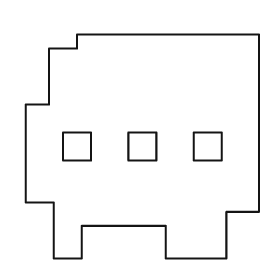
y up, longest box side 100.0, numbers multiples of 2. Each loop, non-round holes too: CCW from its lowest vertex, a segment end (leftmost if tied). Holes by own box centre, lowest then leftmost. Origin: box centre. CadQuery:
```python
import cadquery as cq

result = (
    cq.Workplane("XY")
    .moveTo(-38.0, -48.0)
    .lineTo(-26.0, -48.0)
    .lineTo(-26.0, -34.0)
    .lineTo(10.0, -34.0)
    .lineTo(10.0, -48.0)
    .lineTo(36.0, -48.0)
    .lineTo(36.0, -28.0)
    .lineTo(50.0, -28.0)
    .lineTo(50.0, 48.0)
    .lineTo(-28.0, 48.0)
    .lineTo(-28.0, 42.0)
    .lineTo(-40.0, 42.0)
    .lineTo(-40.0, 18.0)
    .lineTo(-50.0, 18.0)
    .lineTo(-50.0, -24.0)
    .lineTo(-38.0, -24.0)
    .close()
    .moveTo(-34.0, -6.0)
    .lineTo(-22.0, -6.0)
    .lineTo(-22.0, 6.0)
    .lineTo(-34.0, 6.0)
    .close()
    .moveTo(-6.0, -6.0)
    .lineTo(6.0, -6.0)
    .lineTo(6.0, 6.0)
    .lineTo(-6.0, 6.0)
    .close()
    .moveTo(22.0, -6.0)
    .lineTo(34.0, -6.0)
    .lineTo(34.0, 6.0)
    .lineTo(22.0, 6.0)
    .close()
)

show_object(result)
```